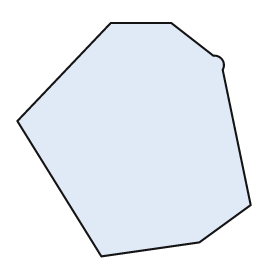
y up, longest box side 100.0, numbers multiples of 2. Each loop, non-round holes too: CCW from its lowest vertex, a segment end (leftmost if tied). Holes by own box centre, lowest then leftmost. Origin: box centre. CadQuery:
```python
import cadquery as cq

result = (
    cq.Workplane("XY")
    .moveTo(-14.0, -50.0)
    .lineTo(28.0, -44.0)
    .lineTo(50.0, -28.0)
    .lineTo(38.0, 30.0)
    .threePointArc((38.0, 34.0), (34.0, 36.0))
    .lineTo(16.0, 50.0)
    .lineTo(-10.0, 50.0)
    .lineTo(-50.0, 8.0)
    .close()
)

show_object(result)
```